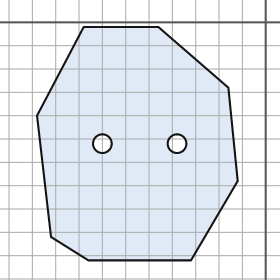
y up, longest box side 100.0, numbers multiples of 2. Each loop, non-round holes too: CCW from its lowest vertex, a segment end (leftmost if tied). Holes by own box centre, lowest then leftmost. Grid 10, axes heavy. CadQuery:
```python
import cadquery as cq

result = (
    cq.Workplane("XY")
    .moveTo(-76.0, -102.0)
    .lineTo(-32.0, -102.0)
    .lineTo(-12.0, -68.0)
    .lineTo(-16.0, -28.0)
    .lineTo(-46.0, -2.0)
    .lineTo(-78.0, -2.0)
    .lineTo(-98.0, -40.0)
    .lineTo(-92.0, -92.0)
    .close()
    .moveTo(-70.0, -52.0)
    .circle(4.0)
    .moveTo(-38.0, -52.0)
    .circle(4.0)
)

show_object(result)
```